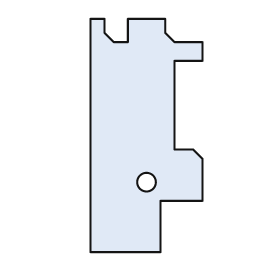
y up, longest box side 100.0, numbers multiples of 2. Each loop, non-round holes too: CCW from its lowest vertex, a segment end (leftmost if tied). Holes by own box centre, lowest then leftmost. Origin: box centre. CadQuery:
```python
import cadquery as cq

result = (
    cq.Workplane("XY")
    .moveTo(-24.0, -50.0)
    .lineTo(6.0, -50.0)
    .lineTo(6.0, -28.0)
    .lineTo(24.0, -28.0)
    .lineTo(24.0, -10.0)
    .lineTo(20.0, -6.0)
    .lineTo(12.0, -6.0)
    .lineTo(12.0, 32.0)
    .lineTo(24.0, 32.0)
    .lineTo(24.0, 40.0)
    .lineTo(12.0, 40.0)
    .lineTo(8.0, 44.0)
    .lineTo(8.0, 50.0)
    .lineTo(-8.0, 50.0)
    .lineTo(-8.0, 40.0)
    .lineTo(-14.0, 40.0)
    .lineTo(-18.0, 44.0)
    .lineTo(-18.0, 50.0)
    .lineTo(-24.0, 50.0)
    .close()
    .moveTo(0.0, -20.0)
    .circle(4.0)
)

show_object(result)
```